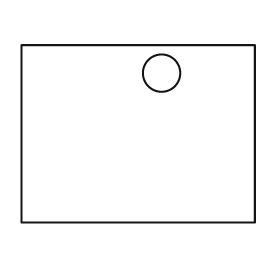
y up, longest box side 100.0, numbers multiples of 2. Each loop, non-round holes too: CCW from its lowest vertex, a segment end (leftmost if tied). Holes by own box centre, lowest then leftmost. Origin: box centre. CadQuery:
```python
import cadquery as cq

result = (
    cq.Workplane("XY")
    .moveTo(-50.0, -38.0)
    .lineTo(50.0, -38.0)
    .lineTo(50.0, 38.0)
    .lineTo(-50.0, 38.0)
    .close()
    .moveTo(10.0, 26.0)
    .circle(8.0)
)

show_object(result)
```